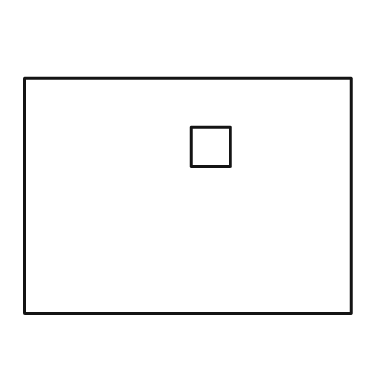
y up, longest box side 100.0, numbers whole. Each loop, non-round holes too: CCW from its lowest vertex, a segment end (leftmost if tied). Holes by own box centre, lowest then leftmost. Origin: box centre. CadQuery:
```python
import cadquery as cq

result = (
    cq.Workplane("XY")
    .moveTo(-50.0, -36.0)
    .lineTo(50.0, -36.0)
    .lineTo(50.0, 36.0)
    .lineTo(-50.0, 36.0)
    .close()
    .moveTo(1.0, 9.0)
    .lineTo(13.0, 9.0)
    .lineTo(13.0, 21.0)
    .lineTo(1.0, 21.0)
    .close()
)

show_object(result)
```